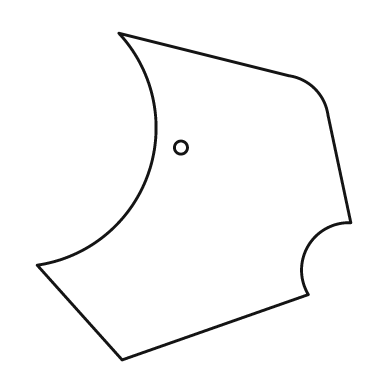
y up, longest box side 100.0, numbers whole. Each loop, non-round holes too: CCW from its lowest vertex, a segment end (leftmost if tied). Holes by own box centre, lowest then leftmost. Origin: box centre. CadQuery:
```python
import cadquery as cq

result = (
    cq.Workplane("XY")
    .moveTo(-22.0, -50.0)
    .lineTo(35.0, -30.0)
    .threePointArc((35.0, -15.0), (48.0, -8.0))
    .lineTo(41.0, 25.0)
    .threePointArc((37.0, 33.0), (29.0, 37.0))
    .lineTo(-23.0, 50.0)
    .threePointArc((-14.0, 7.0), (-48.0, -21.0))
    .close()
    .moveTo(-4.0, 15.0)
    .circle(2.0)
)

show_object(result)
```